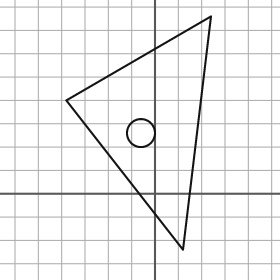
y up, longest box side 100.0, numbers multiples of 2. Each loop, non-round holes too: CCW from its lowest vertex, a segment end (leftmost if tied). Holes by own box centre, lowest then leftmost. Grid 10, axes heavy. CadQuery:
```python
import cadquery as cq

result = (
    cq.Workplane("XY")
    .moveTo(12.0, -24.0)
    .lineTo(24.0, 76.0)
    .lineTo(-38.0, 40.0)
    .close()
    .moveTo(-6.0, 26.0)
    .circle(6.0)
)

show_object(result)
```